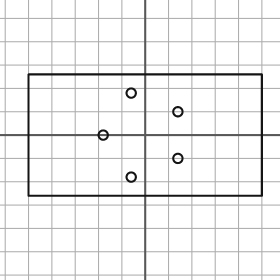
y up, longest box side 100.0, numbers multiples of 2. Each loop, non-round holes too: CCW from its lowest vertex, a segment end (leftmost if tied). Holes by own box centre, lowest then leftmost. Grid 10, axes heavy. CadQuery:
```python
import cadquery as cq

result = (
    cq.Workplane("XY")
    .moveTo(-50.0, -26.0)
    .lineTo(50.0, -26.0)
    .lineTo(50.0, 26.0)
    .lineTo(-50.0, 26.0)
    .close()
    .moveTo(-6.0, -18.0)
    .circle(2.0)
    .moveTo(14.0, -10.0)
    .circle(2.0)
    .moveTo(-18.0, 0.0)
    .circle(2.0)
    .moveTo(14.0, 10.0)
    .circle(2.0)
    .moveTo(-6.0, 18.0)
    .circle(2.0)
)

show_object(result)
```